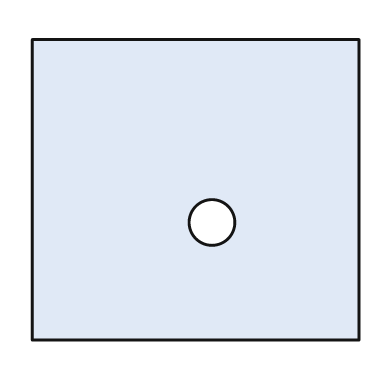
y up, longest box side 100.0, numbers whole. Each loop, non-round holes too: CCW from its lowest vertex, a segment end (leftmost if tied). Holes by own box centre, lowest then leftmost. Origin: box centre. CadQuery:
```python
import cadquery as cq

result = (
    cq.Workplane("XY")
    .moveTo(-50.0, -46.0)
    .lineTo(50.0, -46.0)
    .lineTo(50.0, 46.0)
    .lineTo(-50.0, 46.0)
    .close()
    .moveTo(5.0, -10.0)
    .circle(7.0)
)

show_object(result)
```